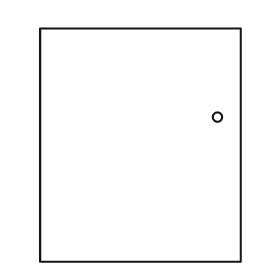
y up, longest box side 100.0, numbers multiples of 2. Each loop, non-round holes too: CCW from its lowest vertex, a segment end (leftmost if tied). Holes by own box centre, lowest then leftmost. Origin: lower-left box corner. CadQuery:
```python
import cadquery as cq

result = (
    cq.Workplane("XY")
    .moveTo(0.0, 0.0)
    .lineTo(86.0, 0.0)
    .lineTo(86.0, 100.0)
    .lineTo(0.0, 100.0)
    .close()
    .moveTo(76.0, 62.0)
    .circle(2.0)
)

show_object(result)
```